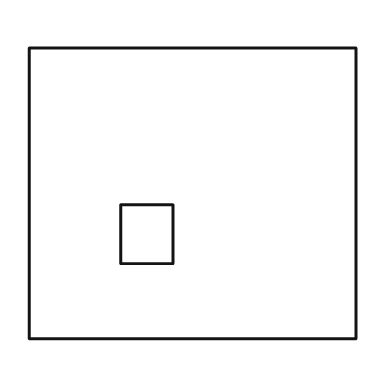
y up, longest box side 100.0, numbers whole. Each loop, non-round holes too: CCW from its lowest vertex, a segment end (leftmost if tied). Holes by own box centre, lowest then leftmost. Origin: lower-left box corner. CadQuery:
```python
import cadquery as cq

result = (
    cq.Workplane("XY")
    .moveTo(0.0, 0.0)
    .lineTo(100.0, 0.0)
    .lineTo(100.0, 89.0)
    .lineTo(0.0, 89.0)
    .close()
    .moveTo(28.0, 23.0)
    .lineTo(44.0, 23.0)
    .lineTo(44.0, 41.0)
    .lineTo(28.0, 41.0)
    .close()
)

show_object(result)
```